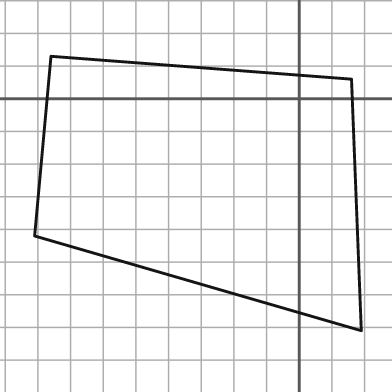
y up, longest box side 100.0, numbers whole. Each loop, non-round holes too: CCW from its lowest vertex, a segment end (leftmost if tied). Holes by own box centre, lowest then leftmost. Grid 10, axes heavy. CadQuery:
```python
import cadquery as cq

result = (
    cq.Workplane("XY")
    .moveTo(19.0, -71.0)
    .lineTo(16.0, 6.0)
    .lineTo(-76.0, 13.0)
    .lineTo(-81.0, -42.0)
    .close()
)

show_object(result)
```